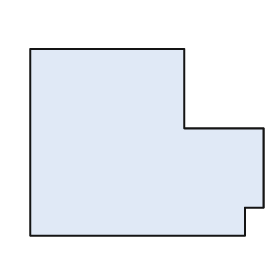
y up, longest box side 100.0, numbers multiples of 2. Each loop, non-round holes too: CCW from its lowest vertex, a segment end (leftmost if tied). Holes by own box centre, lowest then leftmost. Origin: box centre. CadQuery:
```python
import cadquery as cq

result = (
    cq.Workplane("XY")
    .moveTo(-50.0, -40.0)
    .lineTo(42.0, -40.0)
    .lineTo(42.0, -28.0)
    .lineTo(50.0, -28.0)
    .lineTo(50.0, 6.0)
    .lineTo(16.0, 6.0)
    .lineTo(16.0, 40.0)
    .lineTo(-50.0, 40.0)
    .close()
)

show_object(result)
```